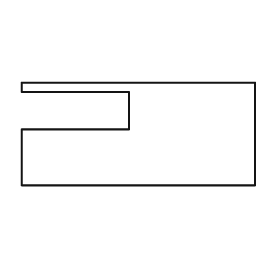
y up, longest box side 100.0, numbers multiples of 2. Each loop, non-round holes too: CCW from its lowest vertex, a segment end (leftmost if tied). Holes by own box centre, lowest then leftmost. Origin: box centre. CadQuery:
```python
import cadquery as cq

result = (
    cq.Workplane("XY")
    .moveTo(-50.0, -22.0)
    .lineTo(50.0, -22.0)
    .lineTo(50.0, 22.0)
    .lineTo(-50.0, 22.0)
    .lineTo(-50.0, 18.0)
    .lineTo(-4.0, 18.0)
    .lineTo(-4.0, 2.0)
    .lineTo(-50.0, 2.0)
    .close()
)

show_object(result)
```